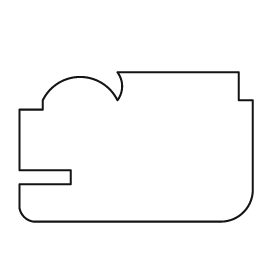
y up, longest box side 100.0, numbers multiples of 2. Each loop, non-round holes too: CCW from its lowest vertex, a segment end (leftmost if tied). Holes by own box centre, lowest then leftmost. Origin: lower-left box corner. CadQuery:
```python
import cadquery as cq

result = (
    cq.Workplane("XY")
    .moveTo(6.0, 0.0)
    .lineTo(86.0, 0.0)
    .threePointArc((96.0, 4.0), (100.0, 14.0))
    .lineTo(100.0, 52.0)
    .lineTo(94.0, 52.0)
    .lineTo(94.0, 64.0)
    .lineTo(42.0, 64.0)
    .threePointArc((44.0, 58.0), (42.0, 52.0))
    .threePointArc((26.0, 62.0), (10.0, 52.0))
    .lineTo(10.0, 48.0)
    .lineTo(0.0, 48.0)
    .lineTo(0.0, 22.0)
    .lineTo(22.0, 22.0)
    .lineTo(22.0, 16.0)
    .lineTo(0.0, 16.0)
    .lineTo(0.0, 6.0)
    .threePointArc((2.0, 2.0), (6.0, 0.0))
    .close()
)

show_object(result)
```